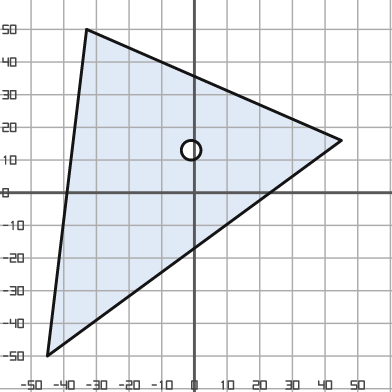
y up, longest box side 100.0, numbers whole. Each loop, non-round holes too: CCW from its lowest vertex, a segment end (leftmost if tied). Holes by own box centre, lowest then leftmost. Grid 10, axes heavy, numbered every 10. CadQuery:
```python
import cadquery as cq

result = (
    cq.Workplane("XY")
    .moveTo(-45.0, -50.0)
    .lineTo(45.0, 16.0)
    .lineTo(-33.0, 50.0)
    .close()
    .moveTo(-1.0, 13.0)
    .circle(3.0)
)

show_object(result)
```